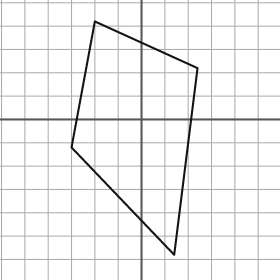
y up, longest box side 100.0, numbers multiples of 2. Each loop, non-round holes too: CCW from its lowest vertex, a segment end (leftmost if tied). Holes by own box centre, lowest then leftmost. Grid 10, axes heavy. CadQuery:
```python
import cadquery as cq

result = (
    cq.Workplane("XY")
    .moveTo(14.0, -58.0)
    .lineTo(24.0, 22.0)
    .lineTo(-20.0, 42.0)
    .lineTo(-30.0, -12.0)
    .close()
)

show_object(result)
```